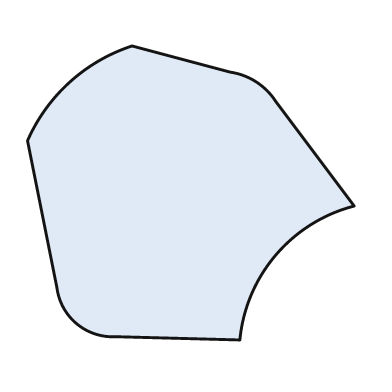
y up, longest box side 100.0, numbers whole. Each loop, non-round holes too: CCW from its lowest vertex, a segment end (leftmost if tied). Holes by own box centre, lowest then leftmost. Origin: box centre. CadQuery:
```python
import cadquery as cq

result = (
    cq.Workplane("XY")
    .moveTo(15.0, -45.0)
    .threePointArc((26.0, -19.0), (50.0, -4.0))
    .lineTo(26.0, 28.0)
    .threePointArc((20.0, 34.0), (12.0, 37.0))
    .lineTo(-18.0, 45.0)
    .threePointArc((-37.0, 34.0), (-50.0, 16.0))
    .lineTo(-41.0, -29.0)
    .threePointArc((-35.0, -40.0), (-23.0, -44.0))
    .close()
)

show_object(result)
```